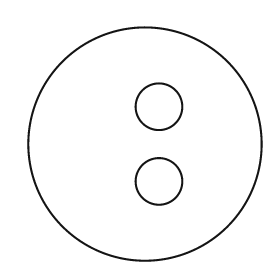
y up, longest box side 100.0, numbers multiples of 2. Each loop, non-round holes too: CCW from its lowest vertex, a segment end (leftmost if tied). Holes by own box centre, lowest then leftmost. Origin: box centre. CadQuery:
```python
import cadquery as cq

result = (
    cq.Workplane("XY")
    .moveTo(0.0, 0.0)
    .circle(50.0)
    .moveTo(6.0, -16.0)
    .circle(10.0)
    .moveTo(6.0, 16.0)
    .circle(10.0)
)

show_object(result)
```